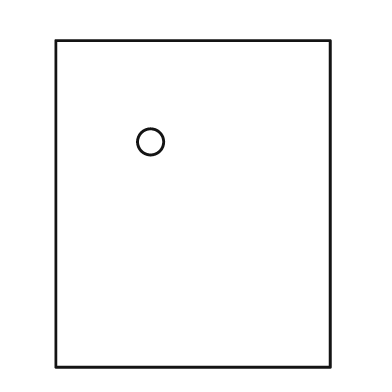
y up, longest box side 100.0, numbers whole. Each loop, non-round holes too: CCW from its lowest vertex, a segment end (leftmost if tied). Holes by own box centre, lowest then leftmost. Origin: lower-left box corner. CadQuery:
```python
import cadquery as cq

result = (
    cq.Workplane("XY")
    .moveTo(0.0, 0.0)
    .lineTo(84.0, 0.0)
    .lineTo(84.0, 100.0)
    .lineTo(0.0, 100.0)
    .close()
    .moveTo(29.0, 69.0)
    .circle(4.0)
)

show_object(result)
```